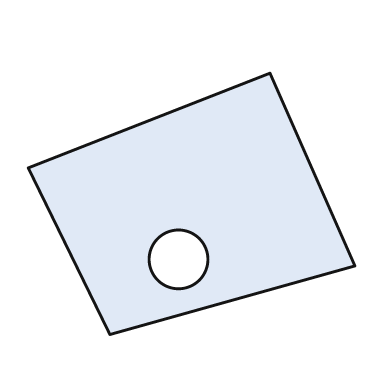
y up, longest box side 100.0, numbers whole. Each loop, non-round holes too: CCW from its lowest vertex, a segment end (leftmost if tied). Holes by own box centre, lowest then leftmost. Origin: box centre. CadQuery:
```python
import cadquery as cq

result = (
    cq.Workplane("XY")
    .moveTo(-25.0, -40.0)
    .lineTo(50.0, -19.0)
    .lineTo(24.0, 40.0)
    .lineTo(-50.0, 11.0)
    .close()
    .moveTo(-4.0, -17.0)
    .circle(9.0)
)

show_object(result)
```